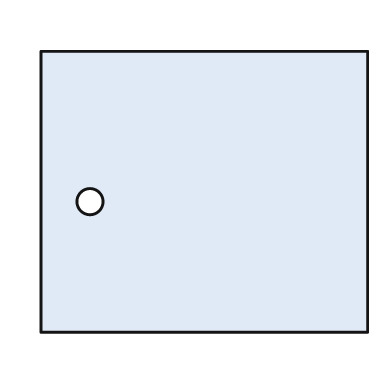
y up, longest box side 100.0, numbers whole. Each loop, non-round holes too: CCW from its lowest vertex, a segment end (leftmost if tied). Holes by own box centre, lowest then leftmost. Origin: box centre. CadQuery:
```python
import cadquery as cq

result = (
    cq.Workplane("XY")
    .moveTo(-50.0, -43.0)
    .lineTo(50.0, -43.0)
    .lineTo(50.0, 43.0)
    .lineTo(-50.0, 43.0)
    .close()
    .moveTo(-35.0, -3.0)
    .circle(4.0)
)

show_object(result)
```